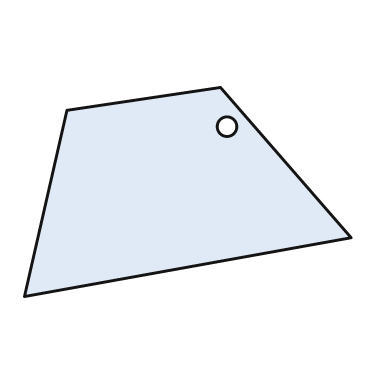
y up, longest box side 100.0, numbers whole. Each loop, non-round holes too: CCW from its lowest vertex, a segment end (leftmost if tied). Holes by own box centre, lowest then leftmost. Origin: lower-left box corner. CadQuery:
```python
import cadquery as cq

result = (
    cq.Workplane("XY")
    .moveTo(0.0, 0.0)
    .lineTo(100.0, 18.0)
    .lineTo(60.0, 64.0)
    .lineTo(13.0, 57.0)
    .close()
    .moveTo(62.0, 52.0)
    .circle(3.0)
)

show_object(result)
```